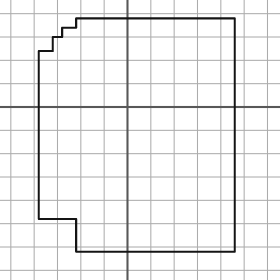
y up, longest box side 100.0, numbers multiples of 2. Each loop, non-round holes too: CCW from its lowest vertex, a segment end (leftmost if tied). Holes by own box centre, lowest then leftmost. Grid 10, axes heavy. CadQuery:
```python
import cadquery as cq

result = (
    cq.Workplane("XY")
    .moveTo(-22.0, -62.0)
    .lineTo(46.0, -62.0)
    .lineTo(46.0, 38.0)
    .lineTo(-22.0, 38.0)
    .lineTo(-22.0, 34.0)
    .lineTo(-28.0, 34.0)
    .lineTo(-28.0, 30.0)
    .lineTo(-32.0, 30.0)
    .lineTo(-32.0, 24.0)
    .lineTo(-38.0, 24.0)
    .lineTo(-38.0, -48.0)
    .lineTo(-22.0, -48.0)
    .close()
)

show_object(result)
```